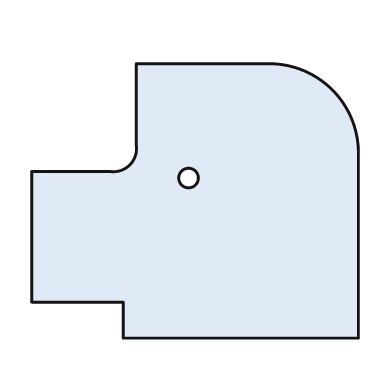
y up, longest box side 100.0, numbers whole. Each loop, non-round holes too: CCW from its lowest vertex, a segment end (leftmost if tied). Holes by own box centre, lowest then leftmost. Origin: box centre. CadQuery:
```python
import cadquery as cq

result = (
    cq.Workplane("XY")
    .moveTo(-22.0, -42.0)
    .lineTo(50.0, -42.0)
    .lineTo(50.0, 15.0)
    .threePointArc((42.0, 34.0), (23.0, 42.0))
    .lineTo(-18.0, 42.0)
    .lineTo(-18.0, 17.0)
    .threePointArc((-20.0, 11.0), (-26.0, 9.0))
    .lineTo(-50.0, 9.0)
    .lineTo(-50.0, -31.0)
    .lineTo(-22.0, -31.0)
    .close()
    .moveTo(-2.0, 7.0)
    .circle(3.0)
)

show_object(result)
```